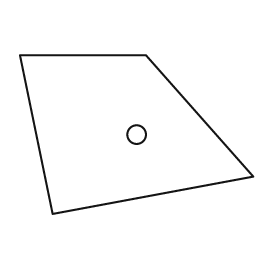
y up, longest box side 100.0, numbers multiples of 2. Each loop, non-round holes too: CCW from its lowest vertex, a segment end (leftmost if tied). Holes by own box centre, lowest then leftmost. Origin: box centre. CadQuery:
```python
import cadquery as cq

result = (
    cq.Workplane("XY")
    .moveTo(-36.0, -34.0)
    .lineTo(50.0, -18.0)
    .lineTo(4.0, 34.0)
    .lineTo(-50.0, 34.0)
    .close()
    .moveTo(0.0, 0.0)
    .circle(4.0)
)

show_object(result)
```